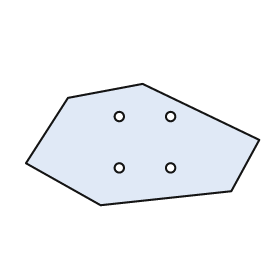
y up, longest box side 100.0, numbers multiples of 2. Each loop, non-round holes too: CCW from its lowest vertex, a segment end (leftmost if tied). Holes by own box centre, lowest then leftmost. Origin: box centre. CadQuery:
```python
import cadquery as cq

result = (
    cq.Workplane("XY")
    .moveTo(-18.0, -26.0)
    .lineTo(38.0, -20.0)
    .lineTo(50.0, 2.0)
    .lineTo(0.0, 26.0)
    .lineTo(-32.0, 20.0)
    .lineTo(-50.0, -8.0)
    .close()
    .moveTo(-10.0, -10.0)
    .circle(2.0)
    .moveTo(12.0, -10.0)
    .circle(2.0)
    .moveTo(-10.0, 12.0)
    .circle(2.0)
    .moveTo(12.0, 12.0)
    .circle(2.0)
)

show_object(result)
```